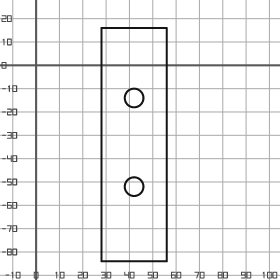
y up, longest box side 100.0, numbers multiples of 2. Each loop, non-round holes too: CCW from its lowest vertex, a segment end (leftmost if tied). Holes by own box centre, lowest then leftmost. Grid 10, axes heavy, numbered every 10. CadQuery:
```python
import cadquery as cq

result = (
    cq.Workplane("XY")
    .moveTo(28.0, -84.0)
    .lineTo(56.0, -84.0)
    .lineTo(56.0, 16.0)
    .lineTo(28.0, 16.0)
    .close()
    .moveTo(42.0, -52.0)
    .circle(4.0)
    .moveTo(42.0, -14.0)
    .circle(4.0)
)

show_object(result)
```